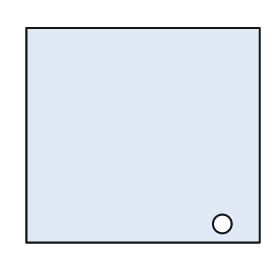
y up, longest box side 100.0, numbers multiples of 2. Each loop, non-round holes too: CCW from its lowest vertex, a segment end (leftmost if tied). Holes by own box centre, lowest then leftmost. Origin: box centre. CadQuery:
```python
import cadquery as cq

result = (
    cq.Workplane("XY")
    .moveTo(-50.0, -46.0)
    .lineTo(50.0, -46.0)
    .lineTo(50.0, 46.0)
    .lineTo(-50.0, 46.0)
    .close()
    .moveTo(34.0, -38.0)
    .circle(4.0)
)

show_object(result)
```